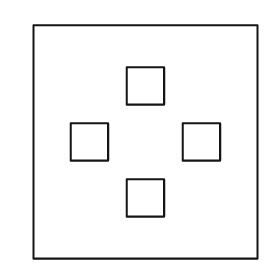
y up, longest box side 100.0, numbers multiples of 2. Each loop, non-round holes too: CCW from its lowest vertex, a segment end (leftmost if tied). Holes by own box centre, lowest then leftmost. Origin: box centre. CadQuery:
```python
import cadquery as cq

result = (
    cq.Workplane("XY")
    .moveTo(-48.0, -50.0)
    .lineTo(48.0, -50.0)
    .lineTo(48.0, 50.0)
    .lineTo(-48.0, 50.0)
    .close()
    .moveTo(-8.0, -32.0)
    .lineTo(8.0, -32.0)
    .lineTo(8.0, -16.0)
    .lineTo(-8.0, -16.0)
    .close()
    .moveTo(-32.0, -8.0)
    .lineTo(-16.0, -8.0)
    .lineTo(-16.0, 8.0)
    .lineTo(-32.0, 8.0)
    .close()
    .moveTo(16.0, -8.0)
    .lineTo(32.0, -8.0)
    .lineTo(32.0, 8.0)
    .lineTo(16.0, 8.0)
    .close()
    .moveTo(-8.0, 16.0)
    .lineTo(8.0, 16.0)
    .lineTo(8.0, 32.0)
    .lineTo(-8.0, 32.0)
    .close()
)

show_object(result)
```